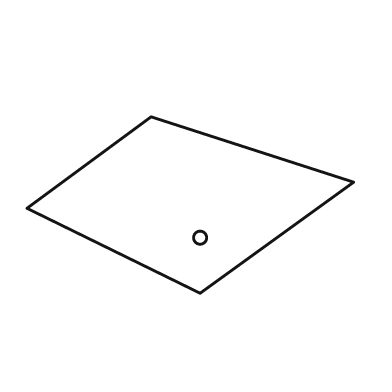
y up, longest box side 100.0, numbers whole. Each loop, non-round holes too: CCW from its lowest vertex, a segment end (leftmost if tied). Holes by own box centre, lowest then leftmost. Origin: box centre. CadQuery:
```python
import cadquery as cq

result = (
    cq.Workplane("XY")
    .moveTo(3.0, -27.0)
    .lineTo(50.0, 7.0)
    .lineTo(-12.0, 27.0)
    .lineTo(-50.0, -1.0)
    .close()
    .moveTo(3.0, -10.0)
    .circle(2.0)
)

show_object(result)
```